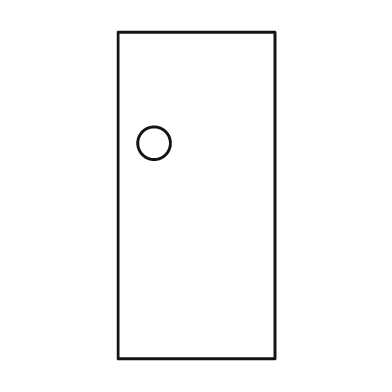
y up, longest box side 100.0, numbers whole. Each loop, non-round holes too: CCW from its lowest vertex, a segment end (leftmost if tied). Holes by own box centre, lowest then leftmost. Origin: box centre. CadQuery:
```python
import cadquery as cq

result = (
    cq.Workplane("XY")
    .moveTo(-24.0, -50.0)
    .lineTo(24.0, -50.0)
    .lineTo(24.0, 50.0)
    .lineTo(-24.0, 50.0)
    .close()
    .moveTo(-13.0, 16.0)
    .circle(5.0)
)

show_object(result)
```